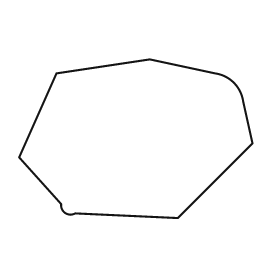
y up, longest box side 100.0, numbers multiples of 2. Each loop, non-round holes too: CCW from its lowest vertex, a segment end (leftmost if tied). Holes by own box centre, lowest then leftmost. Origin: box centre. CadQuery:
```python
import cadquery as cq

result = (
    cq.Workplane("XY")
    .moveTo(18.0, -34.0)
    .lineTo(50.0, -2.0)
    .lineTo(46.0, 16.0)
    .threePointArc((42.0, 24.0), (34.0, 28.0))
    .lineTo(6.0, 34.0)
    .lineTo(-34.0, 28.0)
    .lineTo(-50.0, -8.0)
    .lineTo(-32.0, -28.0)
    .threePointArc((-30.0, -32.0), (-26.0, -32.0))
    .close()
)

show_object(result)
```